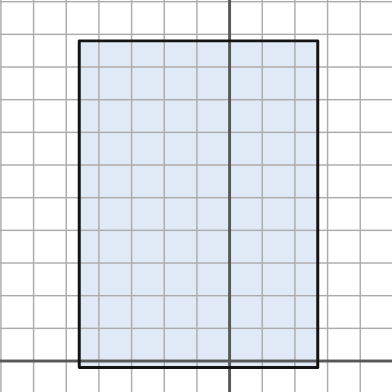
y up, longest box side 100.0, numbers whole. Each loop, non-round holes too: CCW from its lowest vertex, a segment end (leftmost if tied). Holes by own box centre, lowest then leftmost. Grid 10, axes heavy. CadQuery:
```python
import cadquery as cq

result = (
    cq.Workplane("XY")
    .moveTo(-46.0, -2.0)
    .lineTo(27.0, -2.0)
    .lineTo(27.0, 98.0)
    .lineTo(-46.0, 98.0)
    .close()
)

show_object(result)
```